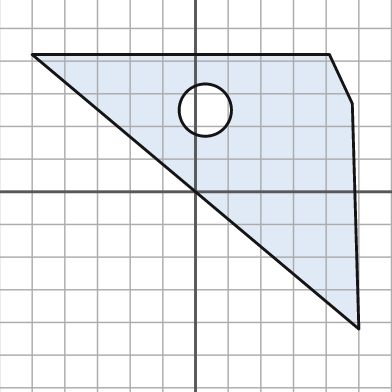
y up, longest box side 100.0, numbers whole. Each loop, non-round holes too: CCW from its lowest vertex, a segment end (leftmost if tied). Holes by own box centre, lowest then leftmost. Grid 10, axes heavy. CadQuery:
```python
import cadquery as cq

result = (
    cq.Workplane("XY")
    .moveTo(50.0, -42.0)
    .lineTo(48.0, 27.0)
    .lineTo(41.0, 42.0)
    .lineTo(-50.0, 42.0)
    .close()
    .moveTo(3.0, 25.0)
    .circle(8.0)
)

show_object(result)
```